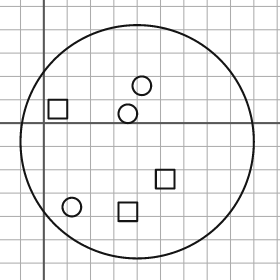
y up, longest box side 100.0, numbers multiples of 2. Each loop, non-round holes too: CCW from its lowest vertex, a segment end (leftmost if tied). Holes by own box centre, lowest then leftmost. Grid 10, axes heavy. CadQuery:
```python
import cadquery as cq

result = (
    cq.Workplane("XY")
    .moveTo(40.0, -8.0)
    .circle(50.0)
    .moveTo(32.0, -42.0)
    .lineTo(40.0, -42.0)
    .lineTo(40.0, -34.0)
    .lineTo(32.0, -34.0)
    .close()
    .moveTo(12.0, -36.0)
    .circle(4.0)
    .moveTo(48.0, -28.0)
    .lineTo(56.0, -28.0)
    .lineTo(56.0, -20.0)
    .lineTo(48.0, -20.0)
    .close()
    .moveTo(36.0, 4.0)
    .circle(4.0)
    .moveTo(2.0, 2.0)
    .lineTo(10.0, 2.0)
    .lineTo(10.0, 10.0)
    .lineTo(2.0, 10.0)
    .close()
    .moveTo(42.0, 16.0)
    .circle(4.0)
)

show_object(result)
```